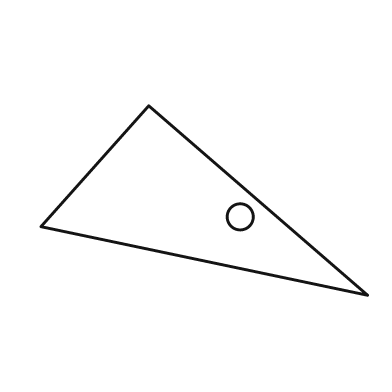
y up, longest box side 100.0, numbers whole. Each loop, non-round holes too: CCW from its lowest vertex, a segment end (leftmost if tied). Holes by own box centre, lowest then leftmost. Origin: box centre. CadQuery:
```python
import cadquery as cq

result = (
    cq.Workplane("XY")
    .moveTo(50.0, -29.0)
    .lineTo(-17.0, 29.0)
    .lineTo(-50.0, -8.0)
    .close()
    .moveTo(11.0, -5.0)
    .circle(4.0)
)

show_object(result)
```